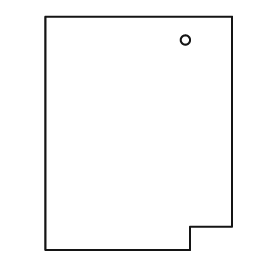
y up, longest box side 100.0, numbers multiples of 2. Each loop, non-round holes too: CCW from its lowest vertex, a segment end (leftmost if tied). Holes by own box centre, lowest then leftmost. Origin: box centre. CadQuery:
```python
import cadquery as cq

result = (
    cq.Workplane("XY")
    .moveTo(-40.0, -50.0)
    .lineTo(22.0, -50.0)
    .lineTo(22.0, -40.0)
    .lineTo(40.0, -40.0)
    .lineTo(40.0, 50.0)
    .lineTo(-40.0, 50.0)
    .close()
    .moveTo(20.0, 40.0)
    .circle(2.0)
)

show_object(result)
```